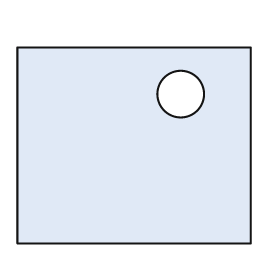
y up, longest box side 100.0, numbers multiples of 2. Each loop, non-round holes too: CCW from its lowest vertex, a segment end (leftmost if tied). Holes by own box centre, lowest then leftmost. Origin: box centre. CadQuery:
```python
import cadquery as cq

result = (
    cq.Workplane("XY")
    .moveTo(-50.0, -42.0)
    .lineTo(50.0, -42.0)
    .lineTo(50.0, 42.0)
    .lineTo(-50.0, 42.0)
    .close()
    .moveTo(20.0, 22.0)
    .circle(10.0)
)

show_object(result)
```